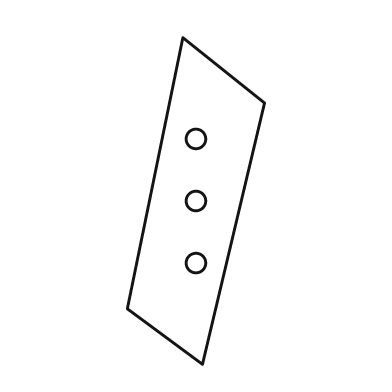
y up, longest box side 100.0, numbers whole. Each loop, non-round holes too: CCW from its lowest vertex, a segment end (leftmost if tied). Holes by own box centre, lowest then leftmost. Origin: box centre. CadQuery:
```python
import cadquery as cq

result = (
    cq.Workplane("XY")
    .moveTo(2.0, -50.0)
    .lineTo(21.0, 30.0)
    .lineTo(-4.0, 50.0)
    .lineTo(-21.0, -33.0)
    .close()
    .moveTo(0.0, -19.0)
    .circle(3.0)
    .moveTo(0.0, 0.0)
    .circle(3.0)
    .moveTo(0.0, 19.0)
    .circle(3.0)
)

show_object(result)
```